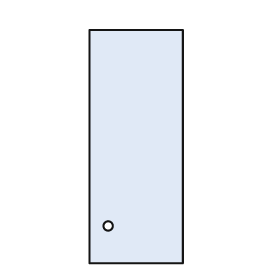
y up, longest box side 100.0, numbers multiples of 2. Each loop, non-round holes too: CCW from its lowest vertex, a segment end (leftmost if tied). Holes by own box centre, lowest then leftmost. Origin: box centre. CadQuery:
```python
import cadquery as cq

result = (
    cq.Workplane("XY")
    .moveTo(-20.0, -50.0)
    .lineTo(20.0, -50.0)
    .lineTo(20.0, 50.0)
    .lineTo(-20.0, 50.0)
    .close()
    .moveTo(-12.0, -34.0)
    .circle(2.0)
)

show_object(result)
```